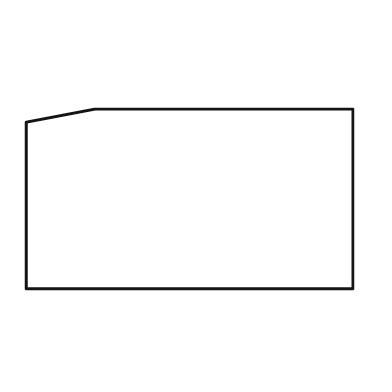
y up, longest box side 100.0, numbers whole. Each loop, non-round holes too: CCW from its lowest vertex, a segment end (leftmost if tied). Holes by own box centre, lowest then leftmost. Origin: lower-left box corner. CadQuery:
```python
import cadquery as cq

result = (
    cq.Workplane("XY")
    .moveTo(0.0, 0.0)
    .lineTo(100.0, 0.0)
    .lineTo(100.0, 55.0)
    .lineTo(21.0, 55.0)
    .lineTo(0.0, 51.0)
    .close()
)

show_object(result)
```